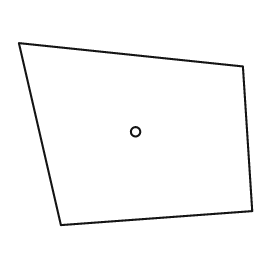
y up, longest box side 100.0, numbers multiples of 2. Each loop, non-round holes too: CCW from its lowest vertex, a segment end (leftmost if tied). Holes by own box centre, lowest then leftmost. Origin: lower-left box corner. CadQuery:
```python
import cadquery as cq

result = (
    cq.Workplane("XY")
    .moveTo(18.0, 0.0)
    .lineTo(100.0, 6.0)
    .lineTo(96.0, 68.0)
    .lineTo(0.0, 78.0)
    .close()
    .moveTo(50.0, 40.0)
    .circle(2.0)
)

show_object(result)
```